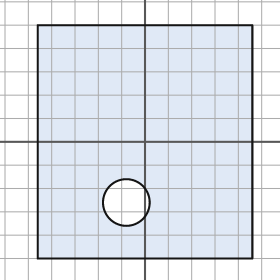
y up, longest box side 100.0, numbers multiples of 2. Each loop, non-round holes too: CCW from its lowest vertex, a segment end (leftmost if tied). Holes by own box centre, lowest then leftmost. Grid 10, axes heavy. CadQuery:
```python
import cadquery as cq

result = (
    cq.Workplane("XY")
    .moveTo(-46.0, -50.0)
    .lineTo(46.0, -50.0)
    .lineTo(46.0, 50.0)
    .lineTo(-46.0, 50.0)
    .close()
    .moveTo(-8.0, -26.0)
    .circle(10.0)
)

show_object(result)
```